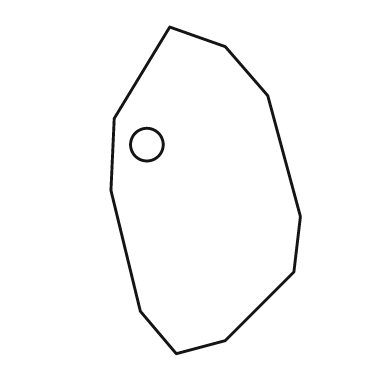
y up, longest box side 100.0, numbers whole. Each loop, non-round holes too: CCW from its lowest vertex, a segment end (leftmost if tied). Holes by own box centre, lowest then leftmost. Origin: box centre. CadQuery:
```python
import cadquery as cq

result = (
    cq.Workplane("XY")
    .moveTo(-9.0, -50.0)
    .lineTo(6.0, -46.0)
    .lineTo(27.0, -25.0)
    .lineTo(29.0, -8.0)
    .lineTo(19.0, 29.0)
    .lineTo(6.0, 44.0)
    .lineTo(-11.0, 50.0)
    .lineTo(-28.0, 22.0)
    .lineTo(-29.0, 0.0)
    .lineTo(-20.0, -37.0)
    .close()
    .moveTo(-18.0, 14.0)
    .circle(5.0)
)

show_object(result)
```